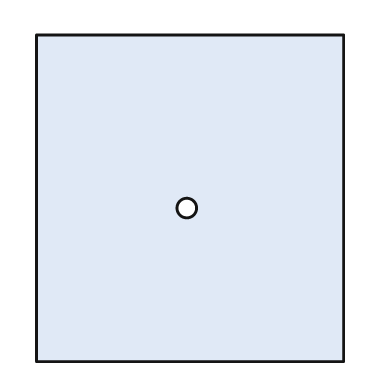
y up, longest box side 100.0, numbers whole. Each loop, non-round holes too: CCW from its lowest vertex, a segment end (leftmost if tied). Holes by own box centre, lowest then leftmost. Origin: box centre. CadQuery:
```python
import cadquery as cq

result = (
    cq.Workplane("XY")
    .moveTo(-47.0, -50.0)
    .lineTo(47.0, -50.0)
    .lineTo(47.0, 50.0)
    .lineTo(-47.0, 50.0)
    .close()
    .moveTo(-1.0, -3.0)
    .circle(3.0)
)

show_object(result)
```